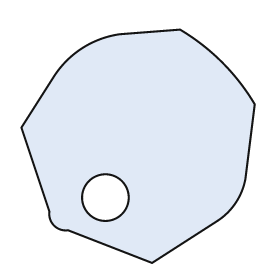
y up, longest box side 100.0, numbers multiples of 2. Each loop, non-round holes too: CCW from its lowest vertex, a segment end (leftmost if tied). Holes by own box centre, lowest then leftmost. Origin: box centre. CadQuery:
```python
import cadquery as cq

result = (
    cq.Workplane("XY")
    .moveTo(6.0, -50.0)
    .lineTo(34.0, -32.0)
    .threePointArc((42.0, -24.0), (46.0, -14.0))
    .lineTo(50.0, 18.0)
    .threePointArc((36.0, 36.0), (18.0, 50.0))
    .lineTo(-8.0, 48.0)
    .threePointArc((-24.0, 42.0), (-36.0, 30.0))
    .lineTo(-50.0, 8.0)
    .lineTo(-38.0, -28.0)
    .threePointArc((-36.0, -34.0), (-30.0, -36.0))
    .close()
    .moveTo(-14.0, -22.0)
    .circle(10.0)
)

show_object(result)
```